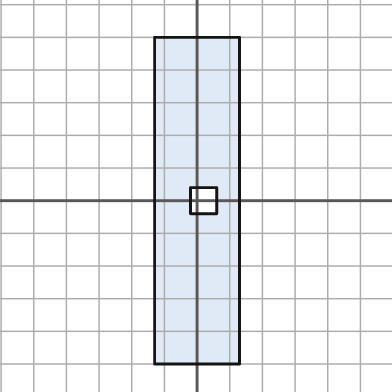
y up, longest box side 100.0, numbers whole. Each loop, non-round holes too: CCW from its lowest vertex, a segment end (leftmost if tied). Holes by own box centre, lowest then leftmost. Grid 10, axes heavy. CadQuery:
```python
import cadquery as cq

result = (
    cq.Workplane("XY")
    .moveTo(-13.0, -50.0)
    .lineTo(13.0, -50.0)
    .lineTo(13.0, 50.0)
    .lineTo(-13.0, 50.0)
    .close()
    .moveTo(-2.0, -4.0)
    .lineTo(6.0, -4.0)
    .lineTo(6.0, 4.0)
    .lineTo(-2.0, 4.0)
    .close()
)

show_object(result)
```